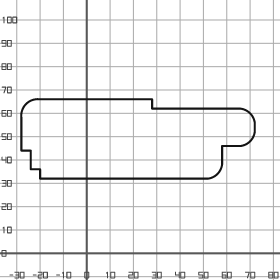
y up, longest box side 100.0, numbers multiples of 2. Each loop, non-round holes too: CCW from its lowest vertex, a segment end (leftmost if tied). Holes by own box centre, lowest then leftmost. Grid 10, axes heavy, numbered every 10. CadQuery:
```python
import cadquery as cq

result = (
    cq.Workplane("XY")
    .moveTo(-20.0, 32.0)
    .lineTo(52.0, 32.0)
    .threePointArc((56.0, 34.0), (58.0, 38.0))
    .lineTo(58.0, 46.0)
    .lineTo(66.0, 46.0)
    .threePointArc((70.0, 48.0), (72.0, 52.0))
    .lineTo(72.0, 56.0)
    .threePointArc((70.0, 60.0), (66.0, 62.0))
    .lineTo(28.0, 62.0)
    .lineTo(28.0, 66.0)
    .lineTo(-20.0, 66.0)
    .threePointArc((-26.0, 64.0), (-28.0, 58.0))
    .lineTo(-28.0, 44.0)
    .lineTo(-24.0, 44.0)
    .lineTo(-24.0, 36.0)
    .lineTo(-20.0, 36.0)
    .close()
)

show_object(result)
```